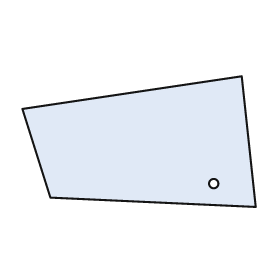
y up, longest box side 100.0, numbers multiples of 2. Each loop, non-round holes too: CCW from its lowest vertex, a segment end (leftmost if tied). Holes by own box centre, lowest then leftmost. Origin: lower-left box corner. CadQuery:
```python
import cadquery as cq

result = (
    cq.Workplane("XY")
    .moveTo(100.0, 0.0)
    .lineTo(94.0, 56.0)
    .lineTo(0.0, 42.0)
    .lineTo(12.0, 4.0)
    .close()
    .moveTo(82.0, 10.0)
    .circle(2.0)
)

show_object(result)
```